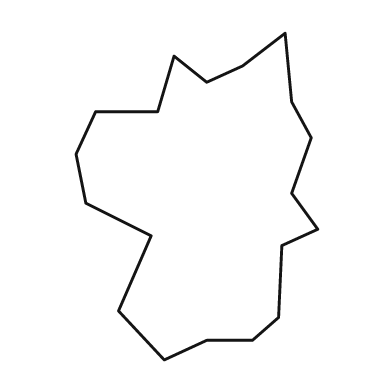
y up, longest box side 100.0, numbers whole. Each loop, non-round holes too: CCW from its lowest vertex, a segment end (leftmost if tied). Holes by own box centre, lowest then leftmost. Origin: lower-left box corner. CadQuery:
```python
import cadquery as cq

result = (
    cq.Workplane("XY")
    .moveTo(27.0, 0.0)
    .lineTo(40.0, 6.0)
    .lineTo(54.0, 6.0)
    .lineTo(62.0, 13.0)
    .lineTo(63.0, 35.0)
    .lineTo(74.0, 40.0)
    .lineTo(66.0, 51.0)
    .lineTo(72.0, 68.0)
    .lineTo(66.0, 79.0)
    .lineTo(64.0, 100.0)
    .lineTo(51.0, 90.0)
    .lineTo(40.0, 85.0)
    .lineTo(30.0, 93.0)
    .lineTo(25.0, 76.0)
    .lineTo(6.0, 76.0)
    .lineTo(0.0, 63.0)
    .lineTo(3.0, 48.0)
    .lineTo(23.0, 38.0)
    .lineTo(13.0, 15.0)
    .close()
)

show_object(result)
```